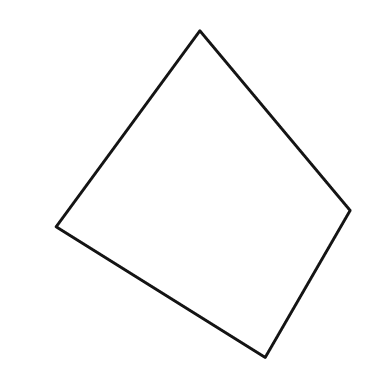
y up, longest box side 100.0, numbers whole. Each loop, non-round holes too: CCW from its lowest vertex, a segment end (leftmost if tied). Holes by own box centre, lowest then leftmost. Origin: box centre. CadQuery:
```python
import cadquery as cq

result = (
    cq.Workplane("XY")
    .moveTo(19.0, -50.0)
    .lineTo(45.0, -5.0)
    .lineTo(-1.0, 50.0)
    .lineTo(-45.0, -10.0)
    .close()
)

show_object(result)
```